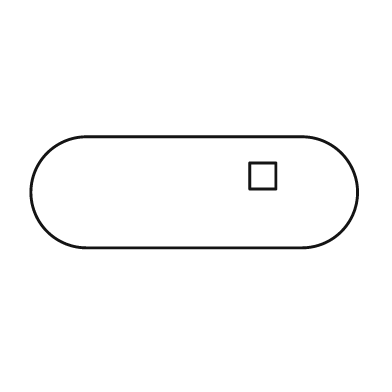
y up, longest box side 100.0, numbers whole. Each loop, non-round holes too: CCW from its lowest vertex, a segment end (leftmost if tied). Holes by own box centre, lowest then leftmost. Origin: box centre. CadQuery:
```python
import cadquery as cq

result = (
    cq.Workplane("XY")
    .moveTo(-33.0, -17.0)
    .lineTo(33.0, -17.0)
    .threePointArc((50.0, 0.0), (33.0, 17.0))
    .lineTo(-33.0, 17.0)
    .threePointArc((-50.0, 0.0), (-33.0, -17.0))
    .close()
    .moveTo(17.0, 1.0)
    .lineTo(25.0, 1.0)
    .lineTo(25.0, 9.0)
    .lineTo(17.0, 9.0)
    .close()
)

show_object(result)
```